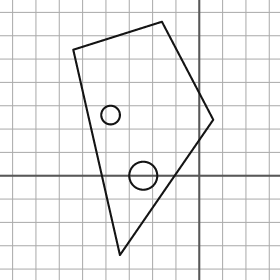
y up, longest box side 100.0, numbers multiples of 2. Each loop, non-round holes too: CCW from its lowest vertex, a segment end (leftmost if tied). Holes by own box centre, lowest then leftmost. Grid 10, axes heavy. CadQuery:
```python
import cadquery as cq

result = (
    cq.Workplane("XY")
    .moveTo(-34.0, -34.0)
    .lineTo(6.0, 24.0)
    .lineTo(-16.0, 66.0)
    .lineTo(-54.0, 54.0)
    .close()
    .moveTo(-24.0, 0.0)
    .circle(6.0)
    .moveTo(-38.0, 26.0)
    .circle(4.0)
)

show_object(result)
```